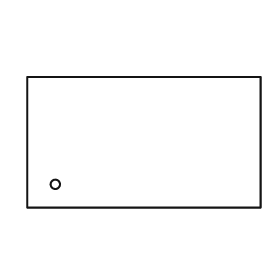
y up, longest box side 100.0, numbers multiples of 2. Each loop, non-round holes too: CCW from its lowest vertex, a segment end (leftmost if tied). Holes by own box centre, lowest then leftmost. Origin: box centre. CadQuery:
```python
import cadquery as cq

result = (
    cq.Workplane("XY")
    .moveTo(-50.0, -28.0)
    .lineTo(50.0, -28.0)
    .lineTo(50.0, 28.0)
    .lineTo(-50.0, 28.0)
    .close()
    .moveTo(-38.0, -18.0)
    .circle(2.0)
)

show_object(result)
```